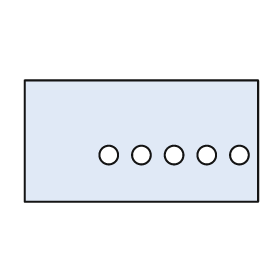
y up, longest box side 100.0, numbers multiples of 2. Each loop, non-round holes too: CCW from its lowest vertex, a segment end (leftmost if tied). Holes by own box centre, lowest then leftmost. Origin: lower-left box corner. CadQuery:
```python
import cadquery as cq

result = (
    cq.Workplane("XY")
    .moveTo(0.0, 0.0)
    .lineTo(100.0, 0.0)
    .lineTo(100.0, 52.0)
    .lineTo(0.0, 52.0)
    .close()
    .moveTo(36.0, 20.0)
    .circle(4.0)
    .moveTo(50.0, 20.0)
    .circle(4.0)
    .moveTo(64.0, 20.0)
    .circle(4.0)
    .moveTo(78.0, 20.0)
    .circle(4.0)
    .moveTo(92.0, 20.0)
    .circle(4.0)
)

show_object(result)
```